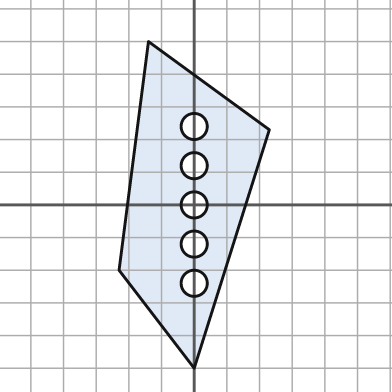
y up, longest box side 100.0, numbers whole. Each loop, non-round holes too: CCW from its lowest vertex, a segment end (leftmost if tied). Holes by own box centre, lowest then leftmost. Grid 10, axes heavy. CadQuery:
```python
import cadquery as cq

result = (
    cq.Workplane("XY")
    .moveTo(0.0, -50.0)
    .lineTo(23.0, 23.0)
    .lineTo(-14.0, 50.0)
    .lineTo(-23.0, -20.0)
    .close()
    .moveTo(0.0, -24.0)
    .circle(4.0)
    .moveTo(0.0, -12.0)
    .circle(4.0)
    .moveTo(0.0, 0.0)
    .circle(4.0)
    .moveTo(0.0, 12.0)
    .circle(4.0)
    .moveTo(0.0, 24.0)
    .circle(4.0)
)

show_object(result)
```